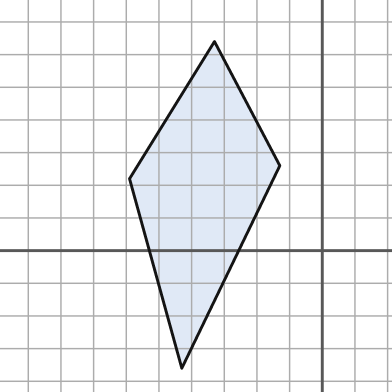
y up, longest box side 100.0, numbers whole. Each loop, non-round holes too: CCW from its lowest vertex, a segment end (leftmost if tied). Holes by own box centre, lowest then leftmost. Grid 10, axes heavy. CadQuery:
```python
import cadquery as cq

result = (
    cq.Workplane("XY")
    .moveTo(-43.0, -36.0)
    .lineTo(-13.0, 26.0)
    .lineTo(-33.0, 64.0)
    .lineTo(-59.0, 22.0)
    .close()
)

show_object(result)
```